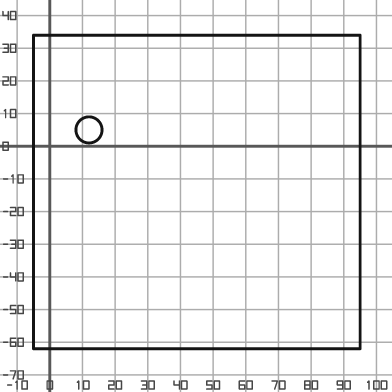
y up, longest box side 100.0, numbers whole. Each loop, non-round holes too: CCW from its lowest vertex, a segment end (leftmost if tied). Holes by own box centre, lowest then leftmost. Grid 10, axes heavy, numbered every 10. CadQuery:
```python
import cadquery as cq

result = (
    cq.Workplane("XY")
    .moveTo(-5.0, -62.0)
    .lineTo(95.0, -62.0)
    .lineTo(95.0, 34.0)
    .lineTo(-5.0, 34.0)
    .close()
    .moveTo(12.0, 5.0)
    .circle(4.0)
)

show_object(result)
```